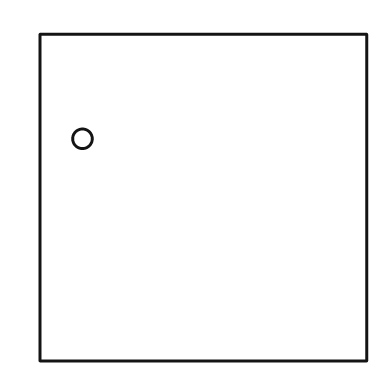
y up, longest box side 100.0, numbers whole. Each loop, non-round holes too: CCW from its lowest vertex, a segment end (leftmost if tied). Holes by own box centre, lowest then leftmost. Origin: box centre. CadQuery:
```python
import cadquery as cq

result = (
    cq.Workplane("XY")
    .moveTo(-50.0, -50.0)
    .lineTo(50.0, -50.0)
    .lineTo(50.0, 50.0)
    .lineTo(-50.0, 50.0)
    .close()
    .moveTo(-37.0, 18.0)
    .circle(3.0)
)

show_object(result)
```